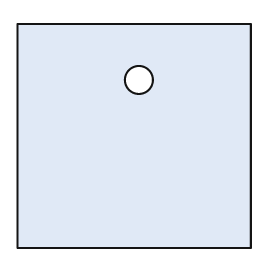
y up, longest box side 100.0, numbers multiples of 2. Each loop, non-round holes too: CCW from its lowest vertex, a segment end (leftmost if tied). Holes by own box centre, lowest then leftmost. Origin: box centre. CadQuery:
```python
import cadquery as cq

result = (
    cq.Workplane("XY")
    .moveTo(-50.0, -48.0)
    .lineTo(50.0, -48.0)
    .lineTo(50.0, 48.0)
    .lineTo(-50.0, 48.0)
    .close()
    .moveTo(2.0, 24.0)
    .circle(6.0)
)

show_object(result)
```